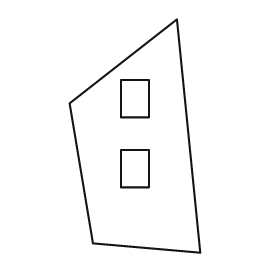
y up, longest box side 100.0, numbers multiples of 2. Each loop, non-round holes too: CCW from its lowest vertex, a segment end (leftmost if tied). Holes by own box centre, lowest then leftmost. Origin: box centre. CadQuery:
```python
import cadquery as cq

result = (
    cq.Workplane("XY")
    .moveTo(28.0, -50.0)
    .lineTo(18.0, 50.0)
    .lineTo(-28.0, 14.0)
    .lineTo(-18.0, -46.0)
    .close()
    .moveTo(-6.0, -22.0)
    .lineTo(6.0, -22.0)
    .lineTo(6.0, -6.0)
    .lineTo(-6.0, -6.0)
    .close()
    .moveTo(-6.0, 8.0)
    .lineTo(6.0, 8.0)
    .lineTo(6.0, 24.0)
    .lineTo(-6.0, 24.0)
    .close()
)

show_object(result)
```